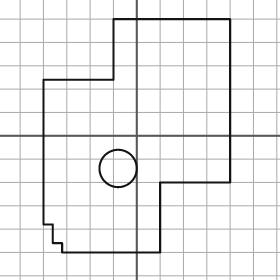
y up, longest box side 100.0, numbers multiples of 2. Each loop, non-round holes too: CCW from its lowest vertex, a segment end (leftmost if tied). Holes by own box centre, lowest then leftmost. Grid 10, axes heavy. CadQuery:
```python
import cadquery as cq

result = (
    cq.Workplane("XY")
    .moveTo(-32.0, -50.0)
    .lineTo(10.0, -50.0)
    .lineTo(10.0, -20.0)
    .lineTo(40.0, -20.0)
    .lineTo(40.0, 50.0)
    .lineTo(-10.0, 50.0)
    .lineTo(-10.0, 24.0)
    .lineTo(-40.0, 24.0)
    .lineTo(-40.0, -38.0)
    .lineTo(-36.0, -38.0)
    .lineTo(-36.0, -46.0)
    .lineTo(-32.0, -46.0)
    .close()
    .moveTo(-8.0, -14.0)
    .circle(8.0)
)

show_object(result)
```